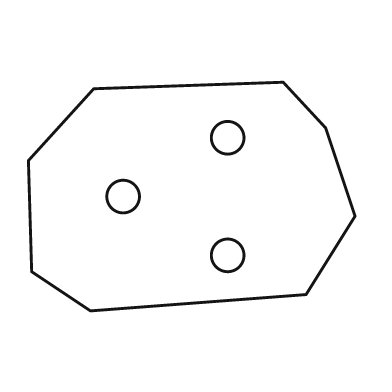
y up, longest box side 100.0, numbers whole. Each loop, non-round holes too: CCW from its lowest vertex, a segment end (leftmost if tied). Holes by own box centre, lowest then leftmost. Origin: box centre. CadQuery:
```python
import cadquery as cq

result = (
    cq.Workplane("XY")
    .moveTo(-31.0, -35.0)
    .lineTo(35.0, -30.0)
    .lineTo(50.0, -6.0)
    .lineTo(41.0, 21.0)
    .lineTo(28.0, 35.0)
    .lineTo(-30.0, 33.0)
    .lineTo(-50.0, 11.0)
    .lineTo(-49.0, -23.0)
    .close()
    .moveTo(11.0, -18.0)
    .circle(5.0)
    .moveTo(-21.0, 0.0)
    .circle(5.0)
    .moveTo(11.0, 18.0)
    .circle(5.0)
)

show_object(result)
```